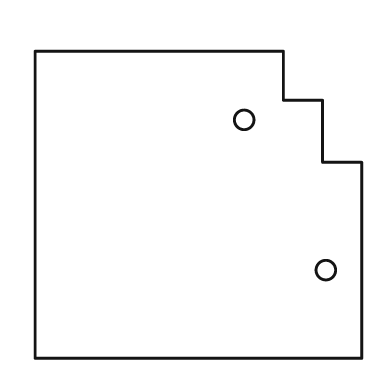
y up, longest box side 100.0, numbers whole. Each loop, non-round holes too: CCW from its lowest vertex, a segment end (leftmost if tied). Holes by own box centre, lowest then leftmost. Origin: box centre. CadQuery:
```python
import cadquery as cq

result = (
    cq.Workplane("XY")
    .moveTo(-50.0, -47.0)
    .lineTo(50.0, -47.0)
    .lineTo(50.0, 13.0)
    .lineTo(38.0, 13.0)
    .lineTo(38.0, 32.0)
    .lineTo(26.0, 32.0)
    .lineTo(26.0, 47.0)
    .lineTo(-50.0, 47.0)
    .close()
    .moveTo(39.0, -20.0)
    .circle(3.0)
    .moveTo(14.0, 26.0)
    .circle(3.0)
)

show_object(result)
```